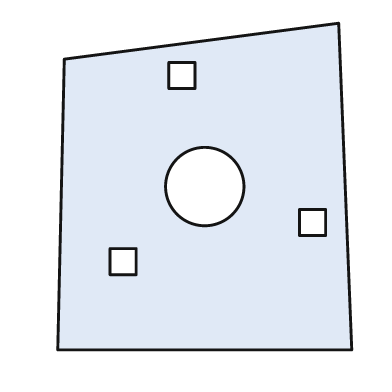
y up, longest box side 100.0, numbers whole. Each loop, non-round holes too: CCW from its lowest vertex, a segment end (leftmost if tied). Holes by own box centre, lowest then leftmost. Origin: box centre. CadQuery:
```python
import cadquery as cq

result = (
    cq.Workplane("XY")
    .moveTo(-45.0, -50.0)
    .lineTo(45.0, -50.0)
    .lineTo(41.0, 50.0)
    .lineTo(-43.0, 39.0)
    .close()
    .moveTo(-29.0, -27.0)
    .lineTo(-21.0, -27.0)
    .lineTo(-21.0, -19.0)
    .lineTo(-29.0, -19.0)
    .close()
    .moveTo(29.0, -15.0)
    .lineTo(37.0, -15.0)
    .lineTo(37.0, -7.0)
    .lineTo(29.0, -7.0)
    .close()
    .moveTo(0.0, 0.0)
    .circle(12.0)
    .moveTo(-11.0, 30.0)
    .lineTo(-3.0, 30.0)
    .lineTo(-3.0, 38.0)
    .lineTo(-11.0, 38.0)
    .close()
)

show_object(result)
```